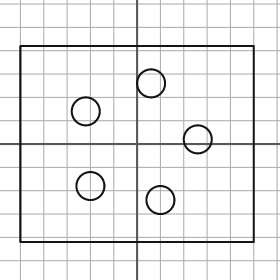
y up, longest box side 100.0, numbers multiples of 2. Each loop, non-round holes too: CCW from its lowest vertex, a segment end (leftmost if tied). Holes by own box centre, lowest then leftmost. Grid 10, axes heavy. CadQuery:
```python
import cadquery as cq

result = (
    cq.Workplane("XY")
    .moveTo(-50.0, -42.0)
    .lineTo(50.0, -42.0)
    .lineTo(50.0, 42.0)
    .lineTo(-50.0, 42.0)
    .close()
    .moveTo(10.0, -24.0)
    .circle(6.0)
    .moveTo(-20.0, -18.0)
    .circle(6.0)
    .moveTo(26.0, 2.0)
    .circle(6.0)
    .moveTo(-22.0, 14.0)
    .circle(6.0)
    .moveTo(6.0, 26.0)
    .circle(6.0)
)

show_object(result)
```